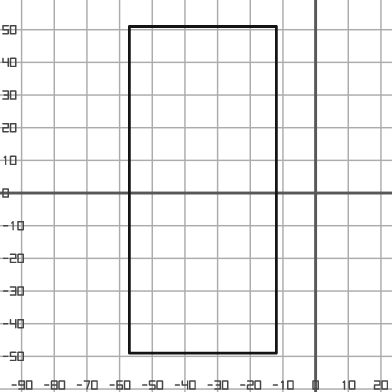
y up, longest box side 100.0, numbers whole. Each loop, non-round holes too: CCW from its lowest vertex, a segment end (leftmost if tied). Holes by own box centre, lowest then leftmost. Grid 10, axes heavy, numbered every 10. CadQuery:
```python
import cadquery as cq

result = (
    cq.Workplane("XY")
    .moveTo(-57.0, -49.0)
    .lineTo(-12.0, -49.0)
    .lineTo(-12.0, 51.0)
    .lineTo(-57.0, 51.0)
    .close()
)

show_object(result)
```